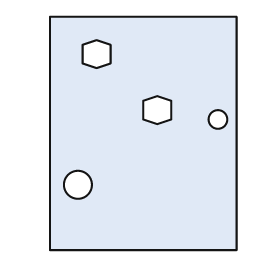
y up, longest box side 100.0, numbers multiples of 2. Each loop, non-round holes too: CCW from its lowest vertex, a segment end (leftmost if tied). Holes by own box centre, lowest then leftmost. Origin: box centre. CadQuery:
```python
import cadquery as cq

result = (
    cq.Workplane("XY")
    .moveTo(-40.0, -50.0)
    .lineTo(40.0, -50.0)
    .lineTo(40.0, 50.0)
    .lineTo(-40.0, 50.0)
    .close()
    .moveTo(-28.0, -22.0)
    .circle(6.0)
    .moveTo(32.0, 6.0)
    .circle(4.0)
    .moveTo(6.0, 4.0)
    .lineTo(12.0, 6.0)
    .lineTo(12.0, 14.0)
    .lineTo(6.0, 16.0)
    .lineTo(0.0, 14.0)
    .lineTo(0.0, 6.0)
    .close()
    .moveTo(-20.0, 28.0)
    .lineTo(-14.0, 30.0)
    .lineTo(-14.0, 38.0)
    .lineTo(-20.0, 40.0)
    .lineTo(-26.0, 38.0)
    .lineTo(-26.0, 30.0)
    .close()
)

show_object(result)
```